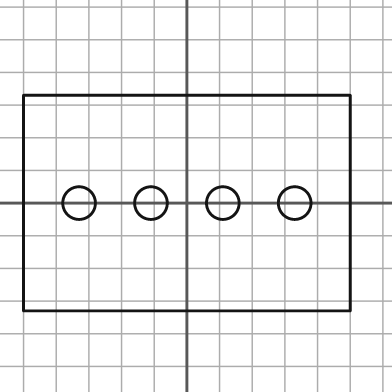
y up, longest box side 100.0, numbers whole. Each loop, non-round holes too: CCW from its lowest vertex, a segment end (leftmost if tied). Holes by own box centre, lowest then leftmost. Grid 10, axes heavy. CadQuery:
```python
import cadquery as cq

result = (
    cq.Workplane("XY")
    .moveTo(-50.0, -33.0)
    .lineTo(50.0, -33.0)
    .lineTo(50.0, 33.0)
    .lineTo(-50.0, 33.0)
    .close()
    .moveTo(-33.0, 0.0)
    .circle(5.0)
    .moveTo(-11.0, 0.0)
    .circle(5.0)
    .moveTo(11.0, 0.0)
    .circle(5.0)
    .moveTo(33.0, 0.0)
    .circle(5.0)
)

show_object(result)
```